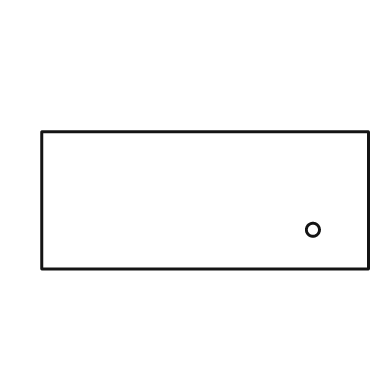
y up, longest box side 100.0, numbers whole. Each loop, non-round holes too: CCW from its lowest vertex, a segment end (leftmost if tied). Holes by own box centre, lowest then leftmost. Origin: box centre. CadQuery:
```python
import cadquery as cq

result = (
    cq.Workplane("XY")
    .moveTo(-50.0, -21.0)
    .lineTo(50.0, -21.0)
    .lineTo(50.0, 21.0)
    .lineTo(-50.0, 21.0)
    .close()
    .moveTo(33.0, -9.0)
    .circle(2.0)
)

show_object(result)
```